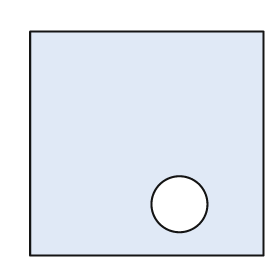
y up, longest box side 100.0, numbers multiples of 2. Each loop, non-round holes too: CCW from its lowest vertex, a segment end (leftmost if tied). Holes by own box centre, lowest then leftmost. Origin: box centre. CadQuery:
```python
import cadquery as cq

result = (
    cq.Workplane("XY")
    .moveTo(-50.0, -48.0)
    .lineTo(50.0, -48.0)
    .lineTo(50.0, 48.0)
    .lineTo(-50.0, 48.0)
    .close()
    .moveTo(14.0, -26.0)
    .circle(12.0)
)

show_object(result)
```